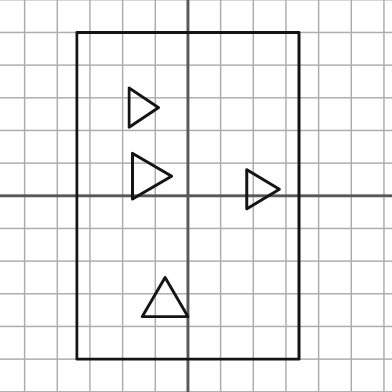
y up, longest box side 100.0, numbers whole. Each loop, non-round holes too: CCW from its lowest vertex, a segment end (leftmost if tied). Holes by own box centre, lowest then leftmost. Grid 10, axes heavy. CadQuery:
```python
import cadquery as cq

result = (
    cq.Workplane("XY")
    .moveTo(-34.0, -50.0)
    .lineTo(34.0, -50.0)
    .lineTo(34.0, 50.0)
    .lineTo(-34.0, 50.0)
    .close()
    .moveTo(-14.0, -37.0)
    .lineTo(0.0, -37.0)
    .lineTo(-7.0, -25.0)
    .close()
    .moveTo(18.0, -4.0)
    .lineTo(28.0, 2.0)
    .lineTo(18.0, 8.0)
    .close()
    .moveTo(-17.0, -1.0)
    .lineTo(-5.0, 6.0)
    .lineTo(-17.0, 13.0)
    .close()
    .moveTo(-18.0, 21.0)
    .lineTo(-9.0, 27.0)
    .lineTo(-18.0, 33.0)
    .close()
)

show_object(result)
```